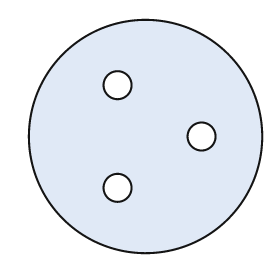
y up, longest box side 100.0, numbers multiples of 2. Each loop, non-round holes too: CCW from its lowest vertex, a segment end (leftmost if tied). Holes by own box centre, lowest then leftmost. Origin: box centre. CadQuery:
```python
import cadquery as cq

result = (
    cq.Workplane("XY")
    .moveTo(0.0, 0.0)
    .circle(50.0)
    .moveTo(-12.0, -22.0)
    .circle(6.0)
    .moveTo(24.0, 0.0)
    .circle(6.0)
    .moveTo(-12.0, 22.0)
    .circle(6.0)
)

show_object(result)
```